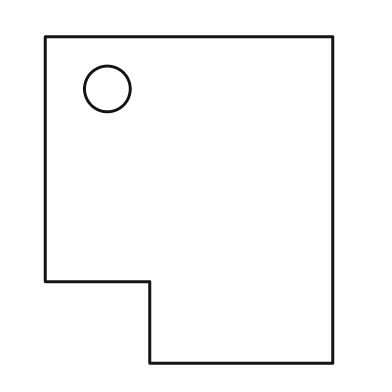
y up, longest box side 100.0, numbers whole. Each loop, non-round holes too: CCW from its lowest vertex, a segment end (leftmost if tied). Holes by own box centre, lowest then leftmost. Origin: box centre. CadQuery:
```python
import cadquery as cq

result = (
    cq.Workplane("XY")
    .moveTo(-12.0, -50.0)
    .lineTo(44.0, -50.0)
    .lineTo(44.0, 50.0)
    .lineTo(-44.0, 50.0)
    .lineTo(-44.0, -25.0)
    .lineTo(-12.0, -25.0)
    .close()
    .moveTo(-25.0, 34.0)
    .circle(7.0)
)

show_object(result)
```